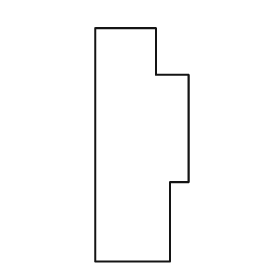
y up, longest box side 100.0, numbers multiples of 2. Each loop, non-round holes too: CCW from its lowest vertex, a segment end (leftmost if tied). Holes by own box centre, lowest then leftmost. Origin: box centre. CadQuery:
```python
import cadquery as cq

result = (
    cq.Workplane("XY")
    .moveTo(-20.0, -50.0)
    .lineTo(12.0, -50.0)
    .lineTo(12.0, -16.0)
    .lineTo(20.0, -16.0)
    .lineTo(20.0, 30.0)
    .lineTo(6.0, 30.0)
    .lineTo(6.0, 50.0)
    .lineTo(-20.0, 50.0)
    .close()
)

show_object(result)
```